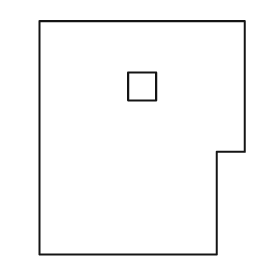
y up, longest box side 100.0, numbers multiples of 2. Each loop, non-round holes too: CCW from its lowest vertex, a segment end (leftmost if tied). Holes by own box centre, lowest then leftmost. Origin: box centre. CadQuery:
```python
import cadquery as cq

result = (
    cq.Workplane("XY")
    .moveTo(-44.0, -50.0)
    .lineTo(32.0, -50.0)
    .lineTo(32.0, -6.0)
    .lineTo(44.0, -6.0)
    .lineTo(44.0, 50.0)
    .lineTo(-44.0, 50.0)
    .close()
    .moveTo(-6.0, 16.0)
    .lineTo(6.0, 16.0)
    .lineTo(6.0, 28.0)
    .lineTo(-6.0, 28.0)
    .close()
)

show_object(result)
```